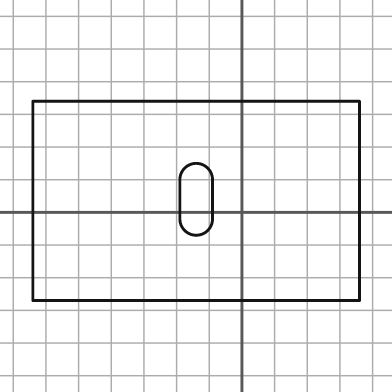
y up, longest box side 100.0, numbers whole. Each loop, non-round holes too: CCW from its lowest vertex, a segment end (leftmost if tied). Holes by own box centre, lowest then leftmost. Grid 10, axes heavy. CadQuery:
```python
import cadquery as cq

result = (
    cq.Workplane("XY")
    .moveTo(-64.0, -27.0)
    .lineTo(36.0, -27.0)
    .lineTo(36.0, 34.0)
    .lineTo(-64.0, 34.0)
    .close()
    .moveTo(-19.0, -2.0)
    .threePointArc((-14.0, -7.0), (-9.0, -2.0))
    .lineTo(-9.0, 10.0)
    .threePointArc((-14.0, 15.0), (-19.0, 10.0))
    .close()
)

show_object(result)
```